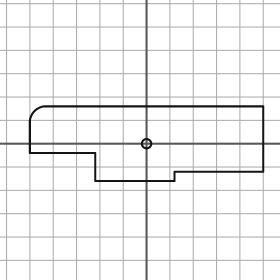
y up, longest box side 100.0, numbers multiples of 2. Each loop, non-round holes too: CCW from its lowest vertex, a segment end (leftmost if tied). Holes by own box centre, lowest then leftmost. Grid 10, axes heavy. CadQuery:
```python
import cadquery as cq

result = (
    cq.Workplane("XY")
    .moveTo(-22.0, -16.0)
    .lineTo(12.0, -16.0)
    .lineTo(12.0, -12.0)
    .lineTo(50.0, -12.0)
    .lineTo(50.0, 16.0)
    .lineTo(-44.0, 16.0)
    .threePointArc((-48.0, 14.0), (-50.0, 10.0))
    .lineTo(-50.0, -4.0)
    .lineTo(-22.0, -4.0)
    .close()
    .moveTo(0.0, 0.0)
    .circle(2.0)
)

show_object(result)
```